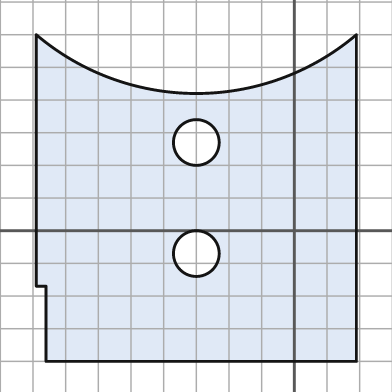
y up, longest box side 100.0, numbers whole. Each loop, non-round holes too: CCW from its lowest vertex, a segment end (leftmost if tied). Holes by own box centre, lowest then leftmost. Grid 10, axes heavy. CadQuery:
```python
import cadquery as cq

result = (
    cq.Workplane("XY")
    .moveTo(-76.0, -40.0)
    .lineTo(19.0, -40.0)
    .lineTo(19.0, 60.0)
    .threePointArc((-30.0, 42.0), (-79.0, 60.0))
    .lineTo(-79.0, -17.0)
    .lineTo(-76.0, -17.0)
    .close()
    .moveTo(-30.0, -7.0)
    .circle(7.0)
    .moveTo(-30.0, 27.0)
    .circle(7.0)
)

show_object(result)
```